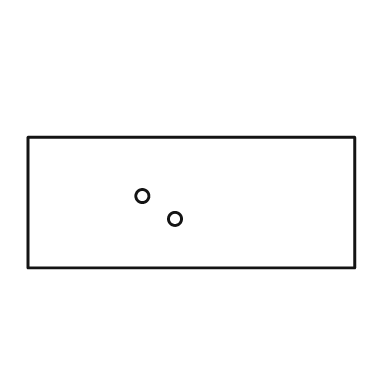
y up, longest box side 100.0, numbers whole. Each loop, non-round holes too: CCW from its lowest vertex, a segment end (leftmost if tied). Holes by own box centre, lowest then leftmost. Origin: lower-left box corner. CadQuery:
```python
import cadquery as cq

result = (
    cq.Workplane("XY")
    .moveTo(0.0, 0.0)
    .lineTo(100.0, 0.0)
    .lineTo(100.0, 40.0)
    .lineTo(0.0, 40.0)
    .close()
    .moveTo(45.0, 15.0)
    .circle(2.0)
    .moveTo(35.0, 22.0)
    .circle(2.0)
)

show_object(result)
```